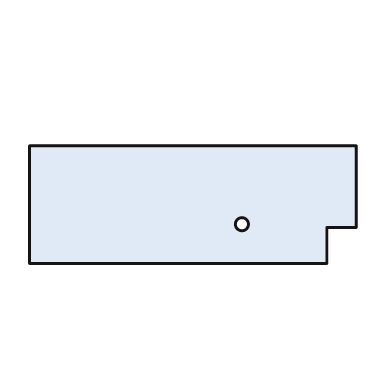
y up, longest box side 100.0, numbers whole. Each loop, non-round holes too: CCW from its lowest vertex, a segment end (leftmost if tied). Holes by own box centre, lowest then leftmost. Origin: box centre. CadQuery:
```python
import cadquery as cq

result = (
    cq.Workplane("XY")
    .moveTo(-50.0, -18.0)
    .lineTo(41.0, -18.0)
    .lineTo(41.0, -7.0)
    .lineTo(50.0, -7.0)
    .lineTo(50.0, 18.0)
    .lineTo(-50.0, 18.0)
    .close()
    .moveTo(15.0, -6.0)
    .circle(2.0)
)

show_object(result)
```